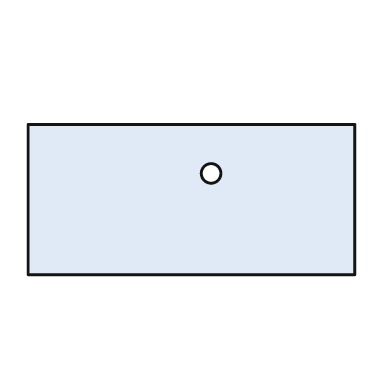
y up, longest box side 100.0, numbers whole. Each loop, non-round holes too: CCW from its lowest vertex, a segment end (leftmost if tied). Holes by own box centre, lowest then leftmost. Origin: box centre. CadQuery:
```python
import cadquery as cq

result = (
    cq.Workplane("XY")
    .moveTo(-50.0, -23.0)
    .lineTo(50.0, -23.0)
    .lineTo(50.0, 23.0)
    .lineTo(-50.0, 23.0)
    .close()
    .moveTo(6.0, 8.0)
    .circle(3.0)
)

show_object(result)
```